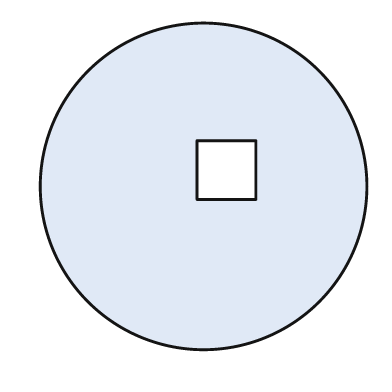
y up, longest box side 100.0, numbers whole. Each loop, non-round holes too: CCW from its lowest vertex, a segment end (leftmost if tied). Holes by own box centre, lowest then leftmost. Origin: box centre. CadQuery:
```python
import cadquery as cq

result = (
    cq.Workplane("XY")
    .moveTo(0.0, 0.0)
    .circle(50.0)
    .moveTo(-2.0, -4.0)
    .lineTo(16.0, -4.0)
    .lineTo(16.0, 14.0)
    .lineTo(-2.0, 14.0)
    .close()
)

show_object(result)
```